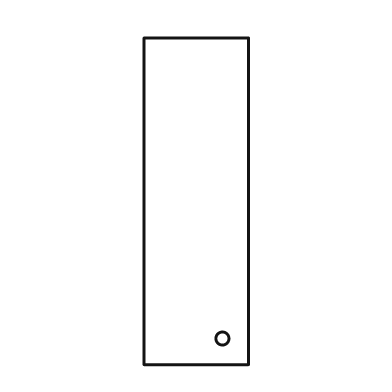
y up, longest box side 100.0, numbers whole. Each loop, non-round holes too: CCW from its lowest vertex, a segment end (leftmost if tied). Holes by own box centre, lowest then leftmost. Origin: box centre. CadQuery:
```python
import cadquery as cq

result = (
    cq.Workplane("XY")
    .moveTo(-16.0, -50.0)
    .lineTo(16.0, -50.0)
    .lineTo(16.0, 50.0)
    .lineTo(-16.0, 50.0)
    .close()
    .moveTo(8.0, -42.0)
    .circle(2.0)
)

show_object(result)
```